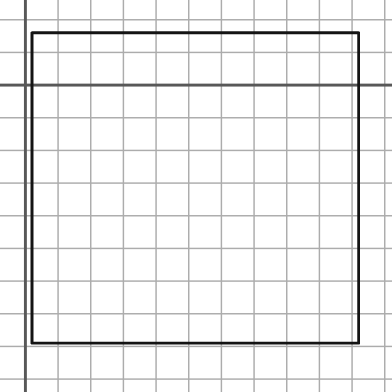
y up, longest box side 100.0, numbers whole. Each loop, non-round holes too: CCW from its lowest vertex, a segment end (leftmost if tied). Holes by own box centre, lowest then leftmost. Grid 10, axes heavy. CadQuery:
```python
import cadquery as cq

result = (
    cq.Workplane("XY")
    .moveTo(2.0, -79.0)
    .lineTo(102.0, -79.0)
    .lineTo(102.0, 16.0)
    .lineTo(2.0, 16.0)
    .close()
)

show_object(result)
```